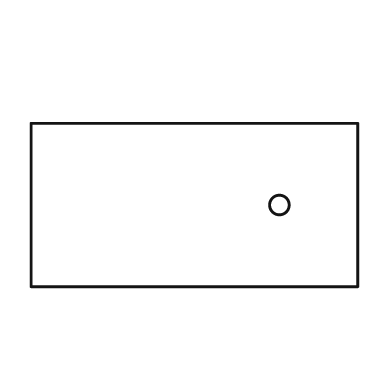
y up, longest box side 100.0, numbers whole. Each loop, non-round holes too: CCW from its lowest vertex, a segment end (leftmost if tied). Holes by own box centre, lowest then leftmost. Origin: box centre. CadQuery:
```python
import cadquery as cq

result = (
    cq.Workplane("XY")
    .moveTo(-50.0, -25.0)
    .lineTo(50.0, -25.0)
    .lineTo(50.0, 25.0)
    .lineTo(-50.0, 25.0)
    .close()
    .moveTo(26.0, 0.0)
    .circle(3.0)
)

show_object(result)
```